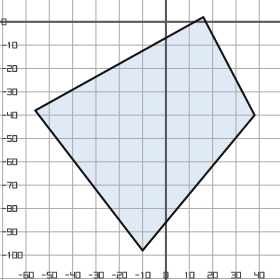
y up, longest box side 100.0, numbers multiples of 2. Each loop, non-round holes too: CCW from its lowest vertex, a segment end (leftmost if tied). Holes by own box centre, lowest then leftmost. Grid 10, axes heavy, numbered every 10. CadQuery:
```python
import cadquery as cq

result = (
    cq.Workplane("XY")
    .moveTo(-10.0, -98.0)
    .lineTo(38.0, -40.0)
    .lineTo(16.0, 2.0)
    .lineTo(-56.0, -38.0)
    .close()
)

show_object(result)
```